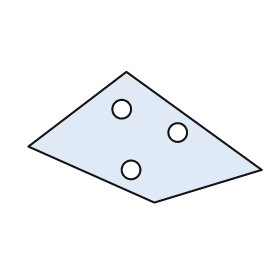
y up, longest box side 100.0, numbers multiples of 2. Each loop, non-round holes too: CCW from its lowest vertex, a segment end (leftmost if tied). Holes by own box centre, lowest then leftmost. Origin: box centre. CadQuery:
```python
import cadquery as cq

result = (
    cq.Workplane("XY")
    .moveTo(4.0, -28.0)
    .lineTo(50.0, -14.0)
    .lineTo(-8.0, 28.0)
    .lineTo(-50.0, -4.0)
    .close()
    .moveTo(-6.0, -14.0)
    .circle(4.0)
    .moveTo(14.0, 2.0)
    .circle(4.0)
    .moveTo(-10.0, 12.0)
    .circle(4.0)
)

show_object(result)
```